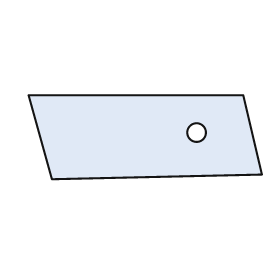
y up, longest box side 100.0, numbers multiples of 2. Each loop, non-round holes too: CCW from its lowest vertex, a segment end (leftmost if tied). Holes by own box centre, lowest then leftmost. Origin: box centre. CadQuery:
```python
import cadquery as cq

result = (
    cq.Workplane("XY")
    .moveTo(-40.0, -18.0)
    .lineTo(50.0, -16.0)
    .lineTo(42.0, 18.0)
    .lineTo(-50.0, 18.0)
    .close()
    .moveTo(22.0, 2.0)
    .circle(4.0)
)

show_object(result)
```